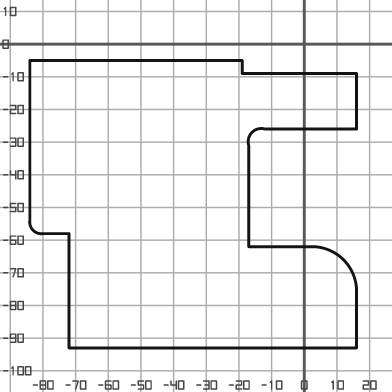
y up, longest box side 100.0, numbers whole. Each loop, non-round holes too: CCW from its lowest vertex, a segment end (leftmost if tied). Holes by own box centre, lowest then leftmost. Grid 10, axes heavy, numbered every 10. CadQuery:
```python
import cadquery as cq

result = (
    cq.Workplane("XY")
    .moveTo(-72.0, -93.0)
    .lineTo(16.0, -93.0)
    .lineTo(16.0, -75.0)
    .threePointArc((12.0, -66.0), (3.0, -62.0))
    .lineTo(-17.0, -62.0)
    .lineTo(-17.0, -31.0)
    .threePointArc((-16.0, -27.0), (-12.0, -26.0))
    .lineTo(16.0, -26.0)
    .lineTo(16.0, -9.0)
    .lineTo(-19.0, -9.0)
    .lineTo(-19.0, -5.0)
    .lineTo(-84.0, -5.0)
    .lineTo(-84.0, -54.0)
    .threePointArc((-83.0, -57.0), (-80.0, -58.0))
    .lineTo(-72.0, -58.0)
    .close()
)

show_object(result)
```